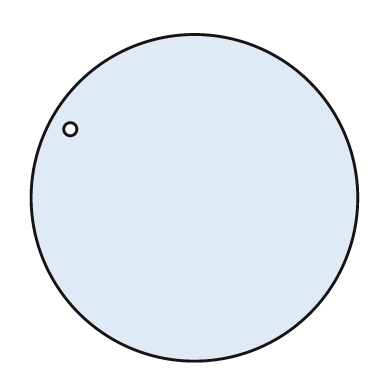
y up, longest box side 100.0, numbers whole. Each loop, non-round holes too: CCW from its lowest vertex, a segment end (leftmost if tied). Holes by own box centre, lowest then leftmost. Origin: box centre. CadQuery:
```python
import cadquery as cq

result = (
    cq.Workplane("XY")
    .moveTo(0.0, 0.0)
    .circle(50.0)
    .moveTo(-38.0, 21.0)
    .circle(2.0)
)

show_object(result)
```